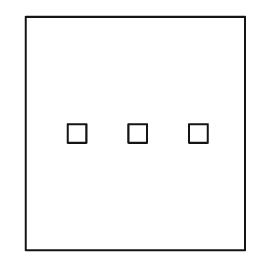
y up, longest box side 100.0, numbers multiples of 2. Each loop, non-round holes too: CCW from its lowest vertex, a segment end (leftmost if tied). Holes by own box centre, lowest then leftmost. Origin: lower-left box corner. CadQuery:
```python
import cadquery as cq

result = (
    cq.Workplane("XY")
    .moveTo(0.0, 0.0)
    .lineTo(94.0, 0.0)
    .lineTo(94.0, 100.0)
    .lineTo(0.0, 100.0)
    .close()
    .moveTo(18.0, 46.0)
    .lineTo(26.0, 46.0)
    .lineTo(26.0, 54.0)
    .lineTo(18.0, 54.0)
    .close()
    .moveTo(44.0, 46.0)
    .lineTo(52.0, 46.0)
    .lineTo(52.0, 54.0)
    .lineTo(44.0, 54.0)
    .close()
    .moveTo(70.0, 46.0)
    .lineTo(78.0, 46.0)
    .lineTo(78.0, 54.0)
    .lineTo(70.0, 54.0)
    .close()
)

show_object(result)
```